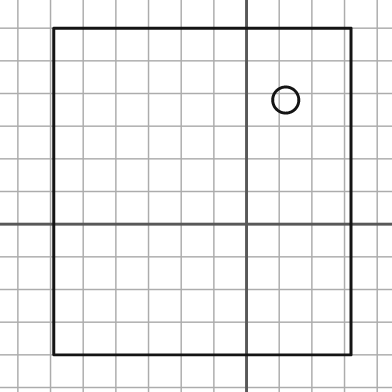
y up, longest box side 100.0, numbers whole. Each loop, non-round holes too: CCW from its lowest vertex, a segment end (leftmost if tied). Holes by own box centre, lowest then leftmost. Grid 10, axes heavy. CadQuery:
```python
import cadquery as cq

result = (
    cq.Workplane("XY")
    .moveTo(-59.0, -40.0)
    .lineTo(32.0, -40.0)
    .lineTo(32.0, 60.0)
    .lineTo(-59.0, 60.0)
    .close()
    .moveTo(12.0, 38.0)
    .circle(4.0)
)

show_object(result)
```